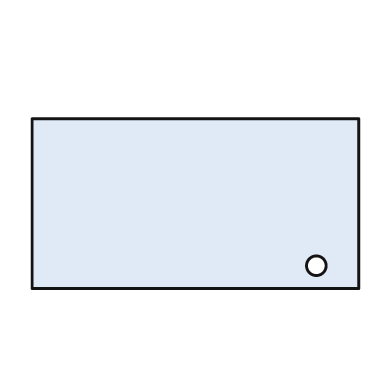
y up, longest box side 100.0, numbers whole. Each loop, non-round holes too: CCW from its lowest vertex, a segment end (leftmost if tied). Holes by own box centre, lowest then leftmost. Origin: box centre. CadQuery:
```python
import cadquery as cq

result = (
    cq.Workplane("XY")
    .moveTo(-50.0, -26.0)
    .lineTo(50.0, -26.0)
    .lineTo(50.0, 26.0)
    .lineTo(-50.0, 26.0)
    .close()
    .moveTo(37.0, -19.0)
    .circle(3.0)
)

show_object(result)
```